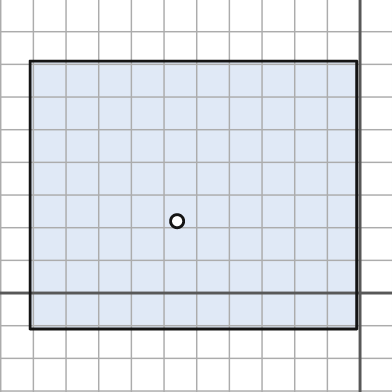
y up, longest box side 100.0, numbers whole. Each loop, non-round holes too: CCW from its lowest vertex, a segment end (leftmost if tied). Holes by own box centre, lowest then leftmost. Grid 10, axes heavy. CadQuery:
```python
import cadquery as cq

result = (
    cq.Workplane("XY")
    .moveTo(-101.0, -11.0)
    .lineTo(-1.0, -11.0)
    .lineTo(-1.0, 71.0)
    .lineTo(-101.0, 71.0)
    .close()
    .moveTo(-56.0, 22.0)
    .circle(2.0)
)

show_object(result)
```